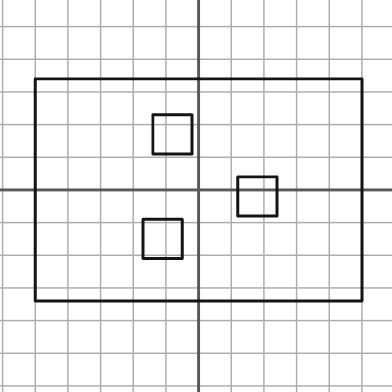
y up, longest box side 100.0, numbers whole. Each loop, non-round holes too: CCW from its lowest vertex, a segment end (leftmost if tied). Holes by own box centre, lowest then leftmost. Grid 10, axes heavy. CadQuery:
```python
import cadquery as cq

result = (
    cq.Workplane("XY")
    .moveTo(-50.0, -34.0)
    .lineTo(50.0, -34.0)
    .lineTo(50.0, 34.0)
    .lineTo(-50.0, 34.0)
    .close()
    .moveTo(-17.0, -21.0)
    .lineTo(-5.0, -21.0)
    .lineTo(-5.0, -9.0)
    .lineTo(-17.0, -9.0)
    .close()
    .moveTo(12.0, -8.0)
    .lineTo(24.0, -8.0)
    .lineTo(24.0, 4.0)
    .lineTo(12.0, 4.0)
    .close()
    .moveTo(-14.0, 11.0)
    .lineTo(-2.0, 11.0)
    .lineTo(-2.0, 23.0)
    .lineTo(-14.0, 23.0)
    .close()
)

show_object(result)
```